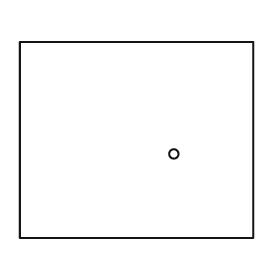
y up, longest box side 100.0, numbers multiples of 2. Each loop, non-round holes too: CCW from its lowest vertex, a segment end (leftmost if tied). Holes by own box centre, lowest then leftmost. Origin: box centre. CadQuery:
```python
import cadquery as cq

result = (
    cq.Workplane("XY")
    .moveTo(-50.0, -42.0)
    .lineTo(50.0, -42.0)
    .lineTo(50.0, 42.0)
    .lineTo(-50.0, 42.0)
    .close()
    .moveTo(16.0, -6.0)
    .circle(2.0)
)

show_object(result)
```